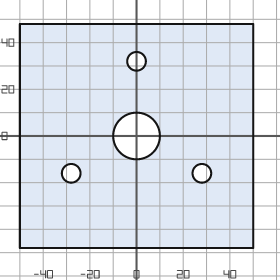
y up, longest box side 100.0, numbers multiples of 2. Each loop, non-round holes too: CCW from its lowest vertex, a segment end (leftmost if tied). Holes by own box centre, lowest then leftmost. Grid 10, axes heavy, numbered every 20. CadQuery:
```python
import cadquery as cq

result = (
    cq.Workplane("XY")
    .moveTo(-50.0, -48.0)
    .lineTo(50.0, -48.0)
    .lineTo(50.0, 48.0)
    .lineTo(-50.0, 48.0)
    .close()
    .moveTo(-28.0, -16.0)
    .circle(4.0)
    .moveTo(28.0, -16.0)
    .circle(4.0)
    .moveTo(0.0, 0.0)
    .circle(10.0)
    .moveTo(0.0, 32.0)
    .circle(4.0)
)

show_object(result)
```